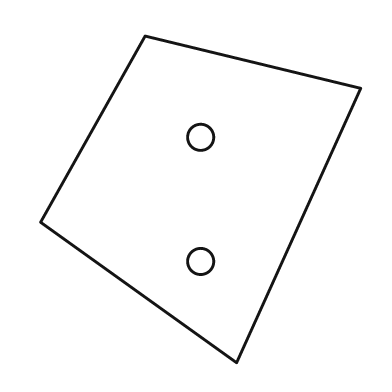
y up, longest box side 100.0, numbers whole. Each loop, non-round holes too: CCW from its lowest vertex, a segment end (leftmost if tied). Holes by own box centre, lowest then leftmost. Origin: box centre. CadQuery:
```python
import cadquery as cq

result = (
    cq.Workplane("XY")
    .moveTo(11.0, -50.0)
    .lineTo(49.0, 34.0)
    .lineTo(-17.0, 50.0)
    .lineTo(-49.0, -7.0)
    .close()
    .moveTo(0.0, -19.0)
    .circle(4.0)
    .moveTo(0.0, 19.0)
    .circle(4.0)
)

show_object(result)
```